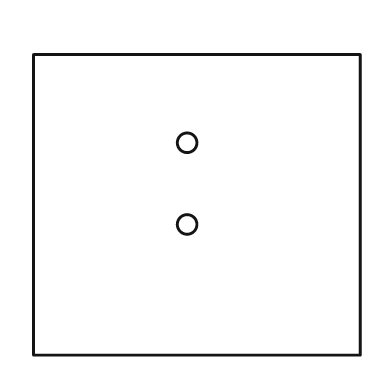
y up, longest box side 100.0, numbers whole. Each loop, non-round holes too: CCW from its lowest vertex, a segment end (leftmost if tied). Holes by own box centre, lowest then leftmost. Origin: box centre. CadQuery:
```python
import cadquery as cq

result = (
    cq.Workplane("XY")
    .moveTo(-50.0, -46.0)
    .lineTo(50.0, -46.0)
    .lineTo(50.0, 46.0)
    .lineTo(-50.0, 46.0)
    .close()
    .moveTo(-3.0, -6.0)
    .circle(3.0)
    .moveTo(-3.0, 19.0)
    .circle(3.0)
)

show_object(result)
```